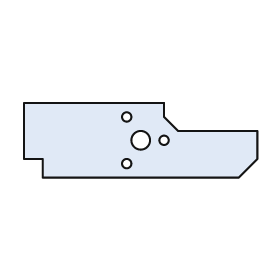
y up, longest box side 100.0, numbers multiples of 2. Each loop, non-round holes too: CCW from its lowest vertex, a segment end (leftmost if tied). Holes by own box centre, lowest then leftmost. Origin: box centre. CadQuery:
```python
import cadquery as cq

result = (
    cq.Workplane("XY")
    .moveTo(-42.0, -16.0)
    .lineTo(42.0, -16.0)
    .lineTo(50.0, -8.0)
    .lineTo(50.0, 4.0)
    .lineTo(16.0, 4.0)
    .lineTo(10.0, 10.0)
    .lineTo(10.0, 16.0)
    .lineTo(-50.0, 16.0)
    .lineTo(-50.0, -8.0)
    .lineTo(-42.0, -8.0)
    .close()
    .moveTo(-6.0, -10.0)
    .circle(2.0)
    .moveTo(0.0, 0.0)
    .circle(4.0)
    .moveTo(10.0, 0.0)
    .circle(2.0)
    .moveTo(-6.0, 10.0)
    .circle(2.0)
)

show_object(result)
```